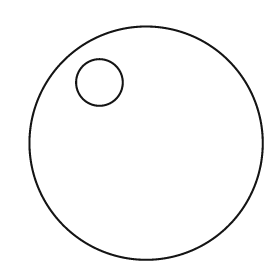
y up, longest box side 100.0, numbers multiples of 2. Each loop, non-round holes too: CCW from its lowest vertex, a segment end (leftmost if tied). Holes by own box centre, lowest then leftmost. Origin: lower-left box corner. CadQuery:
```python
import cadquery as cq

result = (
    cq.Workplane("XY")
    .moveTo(50.0, 50.0)
    .circle(50.0)
    .moveTo(30.0, 76.0)
    .circle(10.0)
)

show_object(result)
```